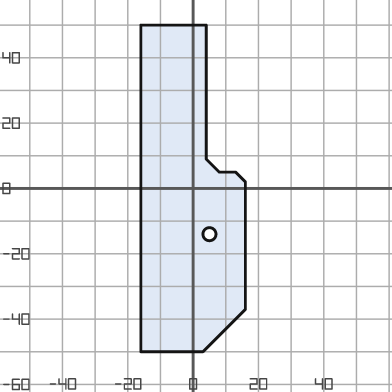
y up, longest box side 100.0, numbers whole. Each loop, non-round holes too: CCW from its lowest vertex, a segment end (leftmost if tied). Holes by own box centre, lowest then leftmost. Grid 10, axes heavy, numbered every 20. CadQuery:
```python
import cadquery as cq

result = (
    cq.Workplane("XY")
    .moveTo(-16.0, -50.0)
    .lineTo(3.0, -50.0)
    .lineTo(16.0, -37.0)
    .lineTo(16.0, 2.0)
    .lineTo(13.0, 5.0)
    .lineTo(8.0, 5.0)
    .lineTo(4.0, 9.0)
    .lineTo(4.0, 50.0)
    .lineTo(-16.0, 50.0)
    .close()
    .moveTo(5.0, -14.0)
    .circle(2.0)
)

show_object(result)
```